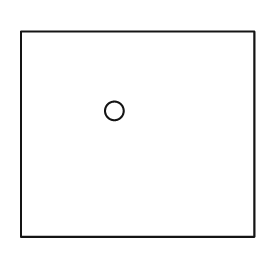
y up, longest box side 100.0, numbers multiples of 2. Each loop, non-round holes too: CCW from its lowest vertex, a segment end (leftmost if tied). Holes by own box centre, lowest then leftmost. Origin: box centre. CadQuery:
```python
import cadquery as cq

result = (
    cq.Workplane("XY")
    .moveTo(-50.0, -44.0)
    .lineTo(50.0, -44.0)
    .lineTo(50.0, 44.0)
    .lineTo(-50.0, 44.0)
    .close()
    .moveTo(-10.0, 10.0)
    .circle(4.0)
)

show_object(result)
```